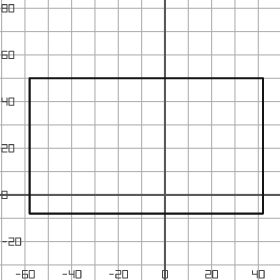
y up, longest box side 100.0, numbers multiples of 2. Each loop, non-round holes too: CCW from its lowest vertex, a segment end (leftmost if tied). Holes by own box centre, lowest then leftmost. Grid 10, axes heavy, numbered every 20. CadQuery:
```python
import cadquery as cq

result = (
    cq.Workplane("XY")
    .moveTo(-58.0, -8.0)
    .lineTo(42.0, -8.0)
    .lineTo(42.0, 50.0)
    .lineTo(-58.0, 50.0)
    .close()
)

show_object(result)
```